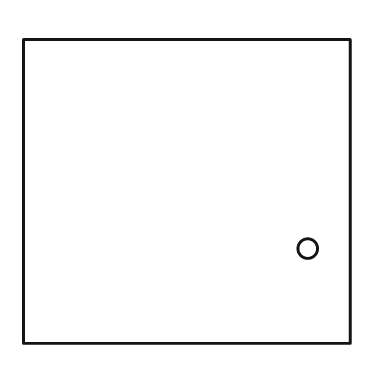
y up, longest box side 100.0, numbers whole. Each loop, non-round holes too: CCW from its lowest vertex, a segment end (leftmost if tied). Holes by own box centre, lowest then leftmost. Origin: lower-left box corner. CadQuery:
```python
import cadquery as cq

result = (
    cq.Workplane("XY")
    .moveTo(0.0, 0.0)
    .lineTo(100.0, 0.0)
    .lineTo(100.0, 93.0)
    .lineTo(0.0, 93.0)
    .close()
    .moveTo(87.0, 29.0)
    .circle(3.0)
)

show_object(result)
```